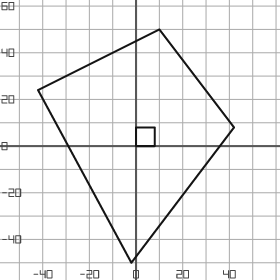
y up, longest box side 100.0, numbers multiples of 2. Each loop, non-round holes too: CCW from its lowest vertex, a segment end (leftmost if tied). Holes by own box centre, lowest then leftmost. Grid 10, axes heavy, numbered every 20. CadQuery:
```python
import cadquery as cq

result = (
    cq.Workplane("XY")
    .moveTo(-2.0, -50.0)
    .lineTo(42.0, 8.0)
    .lineTo(10.0, 50.0)
    .lineTo(-42.0, 24.0)
    .close()
    .moveTo(0.0, 0.0)
    .lineTo(8.0, 0.0)
    .lineTo(8.0, 8.0)
    .lineTo(0.0, 8.0)
    .close()
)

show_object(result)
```